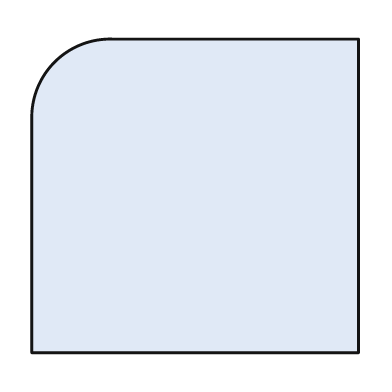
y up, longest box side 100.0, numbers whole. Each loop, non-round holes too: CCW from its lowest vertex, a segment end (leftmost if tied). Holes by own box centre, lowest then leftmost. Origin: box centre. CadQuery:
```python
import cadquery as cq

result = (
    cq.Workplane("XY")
    .moveTo(-50.0, -48.0)
    .lineTo(50.0, -48.0)
    .lineTo(50.0, 48.0)
    .lineTo(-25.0, 48.0)
    .threePointArc((-43.0, 41.0), (-50.0, 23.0))
    .close()
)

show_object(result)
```